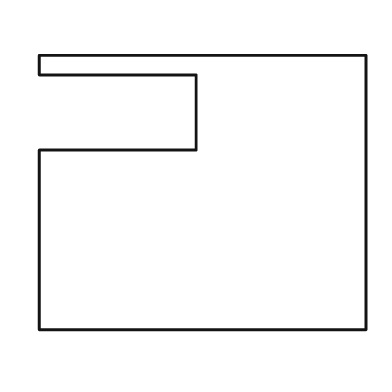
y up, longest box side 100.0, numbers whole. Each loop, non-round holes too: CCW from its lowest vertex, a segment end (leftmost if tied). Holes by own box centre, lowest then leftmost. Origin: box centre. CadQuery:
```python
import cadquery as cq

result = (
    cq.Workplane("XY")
    .moveTo(-50.0, -42.0)
    .lineTo(50.0, -42.0)
    .lineTo(50.0, 42.0)
    .lineTo(-50.0, 42.0)
    .lineTo(-50.0, 36.0)
    .lineTo(-2.0, 36.0)
    .lineTo(-2.0, 13.0)
    .lineTo(-50.0, 13.0)
    .close()
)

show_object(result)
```